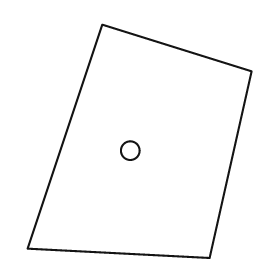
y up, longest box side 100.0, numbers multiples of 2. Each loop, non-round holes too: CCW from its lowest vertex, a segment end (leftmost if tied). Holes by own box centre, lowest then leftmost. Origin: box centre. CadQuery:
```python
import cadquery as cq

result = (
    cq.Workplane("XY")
    .moveTo(30.0, -50.0)
    .lineTo(48.0, 30.0)
    .lineTo(-16.0, 50.0)
    .lineTo(-48.0, -46.0)
    .close()
    .moveTo(-4.0, -4.0)
    .circle(4.0)
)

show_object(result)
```